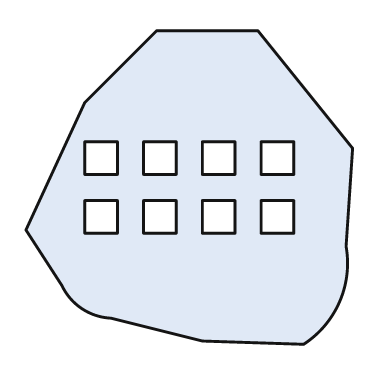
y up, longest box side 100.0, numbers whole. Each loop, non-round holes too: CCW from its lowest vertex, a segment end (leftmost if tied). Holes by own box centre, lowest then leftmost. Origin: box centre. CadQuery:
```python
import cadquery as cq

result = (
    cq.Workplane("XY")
    .moveTo(35.0, -48.0)
    .threePointArc((46.0, -35.0), (48.0, -18.0))
    .lineTo(50.0, 12.0)
    .lineTo(21.0, 48.0)
    .lineTo(-10.0, 48.0)
    .lineTo(-32.0, 26.0)
    .lineTo(-50.0, -13.0)
    .lineTo(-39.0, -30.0)
    .threePointArc((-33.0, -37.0), (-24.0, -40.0))
    .lineTo(4.0, -47.0)
    .close()
    .moveTo(-32.0, -14.0)
    .lineTo(-22.0, -14.0)
    .lineTo(-22.0, -4.0)
    .lineTo(-32.0, -4.0)
    .close()
    .moveTo(-14.0, -14.0)
    .lineTo(-4.0, -14.0)
    .lineTo(-4.0, -4.0)
    .lineTo(-14.0, -4.0)
    .close()
    .moveTo(4.0, -14.0)
    .lineTo(14.0, -14.0)
    .lineTo(14.0, -4.0)
    .lineTo(4.0, -4.0)
    .close()
    .moveTo(22.0, -14.0)
    .lineTo(32.0, -14.0)
    .lineTo(32.0, -4.0)
    .lineTo(22.0, -4.0)
    .close()
    .moveTo(-32.0, 4.0)
    .lineTo(-22.0, 4.0)
    .lineTo(-22.0, 14.0)
    .lineTo(-32.0, 14.0)
    .close()
    .moveTo(-14.0, 4.0)
    .lineTo(-4.0, 4.0)
    .lineTo(-4.0, 14.0)
    .lineTo(-14.0, 14.0)
    .close()
    .moveTo(4.0, 4.0)
    .lineTo(14.0, 4.0)
    .lineTo(14.0, 14.0)
    .lineTo(4.0, 14.0)
    .close()
    .moveTo(22.0, 4.0)
    .lineTo(32.0, 4.0)
    .lineTo(32.0, 14.0)
    .lineTo(22.0, 14.0)
    .close()
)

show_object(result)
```